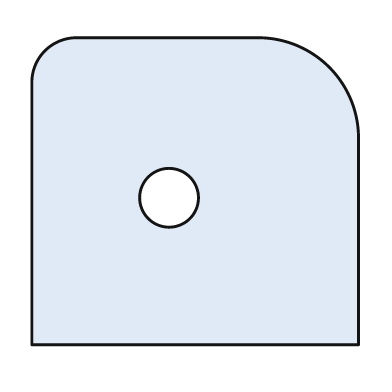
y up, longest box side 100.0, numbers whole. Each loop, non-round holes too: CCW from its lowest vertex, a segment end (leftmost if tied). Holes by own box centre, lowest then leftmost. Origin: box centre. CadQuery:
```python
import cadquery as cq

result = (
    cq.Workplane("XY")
    .moveTo(-50.0, -47.0)
    .lineTo(50.0, -47.0)
    .lineTo(50.0, 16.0)
    .threePointArc((41.0, 38.0), (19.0, 47.0))
    .lineTo(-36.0, 47.0)
    .threePointArc((-46.0, 43.0), (-50.0, 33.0))
    .close()
    .moveTo(-8.0, -2.0)
    .circle(9.0)
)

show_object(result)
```